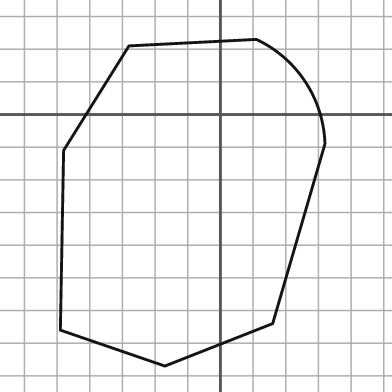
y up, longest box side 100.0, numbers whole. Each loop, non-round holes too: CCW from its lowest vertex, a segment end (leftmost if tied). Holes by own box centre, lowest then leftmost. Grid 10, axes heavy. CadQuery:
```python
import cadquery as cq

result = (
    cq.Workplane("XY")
    .moveTo(-17.0, -77.0)
    .lineTo(16.0, -64.0)
    .lineTo(32.0, -9.0)
    .threePointArc((26.0, 10.0), (11.0, 23.0))
    .lineTo(-28.0, 21.0)
    .lineTo(-48.0, -11.0)
    .lineTo(-49.0, -66.0)
    .close()
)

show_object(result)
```